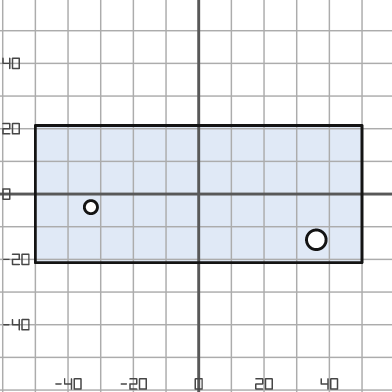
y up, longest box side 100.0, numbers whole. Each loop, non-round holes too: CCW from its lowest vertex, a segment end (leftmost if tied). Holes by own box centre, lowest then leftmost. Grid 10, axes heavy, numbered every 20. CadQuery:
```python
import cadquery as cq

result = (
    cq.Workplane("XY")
    .moveTo(-50.0, -21.0)
    .lineTo(50.0, -21.0)
    .lineTo(50.0, 21.0)
    .lineTo(-50.0, 21.0)
    .close()
    .moveTo(36.0, -14.0)
    .circle(3.0)
    .moveTo(-33.0, -4.0)
    .circle(2.0)
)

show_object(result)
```